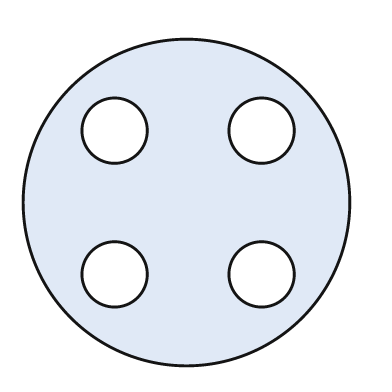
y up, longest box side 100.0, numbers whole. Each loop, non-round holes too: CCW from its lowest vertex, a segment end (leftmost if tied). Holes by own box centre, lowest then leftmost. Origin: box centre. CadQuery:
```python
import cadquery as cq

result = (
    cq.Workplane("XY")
    .moveTo(0.0, 0.0)
    .circle(50.0)
    .moveTo(-22.0, -22.0)
    .circle(10.0)
    .moveTo(23.0, -22.0)
    .circle(10.0)
    .moveTo(-22.0, 22.0)
    .circle(10.0)
    .moveTo(23.0, 22.0)
    .circle(10.0)
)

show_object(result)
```